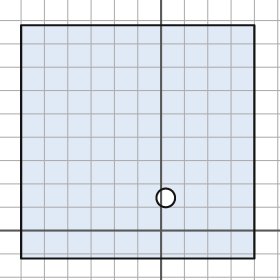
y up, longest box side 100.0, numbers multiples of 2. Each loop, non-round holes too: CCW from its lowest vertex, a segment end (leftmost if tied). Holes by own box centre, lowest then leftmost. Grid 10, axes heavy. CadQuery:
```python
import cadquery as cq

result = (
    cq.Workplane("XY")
    .moveTo(-60.0, -12.0)
    .lineTo(40.0, -12.0)
    .lineTo(40.0, 88.0)
    .lineTo(-60.0, 88.0)
    .close()
    .moveTo(2.0, 14.0)
    .circle(4.0)
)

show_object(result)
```